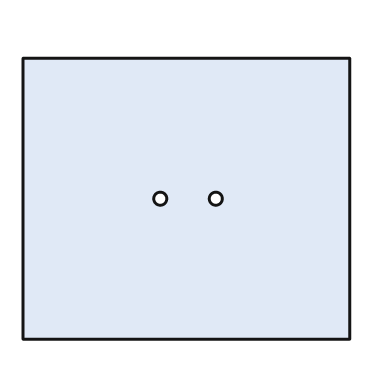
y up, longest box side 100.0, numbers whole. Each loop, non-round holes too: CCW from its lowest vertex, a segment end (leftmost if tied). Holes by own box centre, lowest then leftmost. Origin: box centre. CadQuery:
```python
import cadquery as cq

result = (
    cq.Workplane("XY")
    .moveTo(-50.0, -43.0)
    .lineTo(50.0, -43.0)
    .lineTo(50.0, 43.0)
    .lineTo(-50.0, 43.0)
    .close()
    .moveTo(-8.0, 0.0)
    .circle(2.0)
    .moveTo(9.0, 0.0)
    .circle(2.0)
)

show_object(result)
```